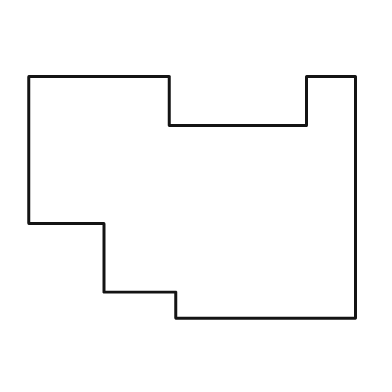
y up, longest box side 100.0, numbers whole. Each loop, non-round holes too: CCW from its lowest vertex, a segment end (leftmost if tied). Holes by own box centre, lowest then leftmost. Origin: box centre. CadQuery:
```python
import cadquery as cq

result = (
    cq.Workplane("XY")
    .moveTo(-5.0, -37.0)
    .lineTo(50.0, -37.0)
    .lineTo(50.0, 37.0)
    .lineTo(35.0, 37.0)
    .lineTo(35.0, 22.0)
    .lineTo(-7.0, 22.0)
    .lineTo(-7.0, 37.0)
    .lineTo(-50.0, 37.0)
    .lineTo(-50.0, -8.0)
    .lineTo(-27.0, -8.0)
    .lineTo(-27.0, -29.0)
    .lineTo(-5.0, -29.0)
    .close()
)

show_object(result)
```